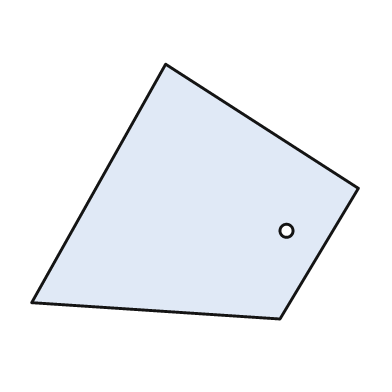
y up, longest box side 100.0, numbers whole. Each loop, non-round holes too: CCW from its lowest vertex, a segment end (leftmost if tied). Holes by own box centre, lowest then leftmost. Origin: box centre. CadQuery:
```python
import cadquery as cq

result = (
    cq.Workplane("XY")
    .moveTo(26.0, -39.0)
    .lineTo(50.0, 1.0)
    .lineTo(-9.0, 39.0)
    .lineTo(-50.0, -34.0)
    .close()
    .moveTo(28.0, -12.0)
    .circle(2.0)
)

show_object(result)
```